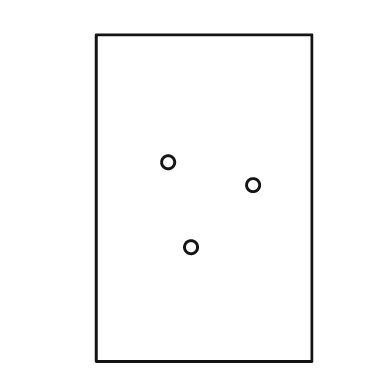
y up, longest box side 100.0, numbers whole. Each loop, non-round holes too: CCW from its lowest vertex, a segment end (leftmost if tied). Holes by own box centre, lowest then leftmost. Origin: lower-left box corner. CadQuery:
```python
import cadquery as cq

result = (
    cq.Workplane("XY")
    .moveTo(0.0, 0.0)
    .lineTo(66.0, 0.0)
    .lineTo(66.0, 100.0)
    .lineTo(0.0, 100.0)
    .close()
    .moveTo(29.0, 35.0)
    .circle(2.0)
    .moveTo(48.0, 54.0)
    .circle(2.0)
    .moveTo(22.0, 61.0)
    .circle(2.0)
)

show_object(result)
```